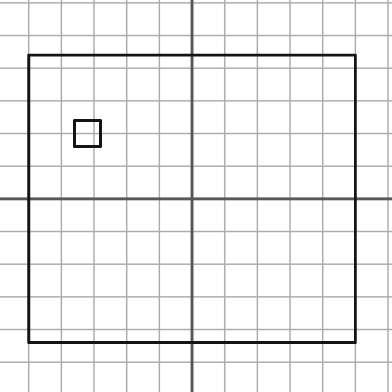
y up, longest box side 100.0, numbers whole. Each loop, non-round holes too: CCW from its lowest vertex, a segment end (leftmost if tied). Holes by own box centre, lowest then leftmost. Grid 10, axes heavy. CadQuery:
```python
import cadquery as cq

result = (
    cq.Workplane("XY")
    .moveTo(-50.0, -44.0)
    .lineTo(50.0, -44.0)
    .lineTo(50.0, 44.0)
    .lineTo(-50.0, 44.0)
    .close()
    .moveTo(-36.0, 16.0)
    .lineTo(-28.0, 16.0)
    .lineTo(-28.0, 24.0)
    .lineTo(-36.0, 24.0)
    .close()
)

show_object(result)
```